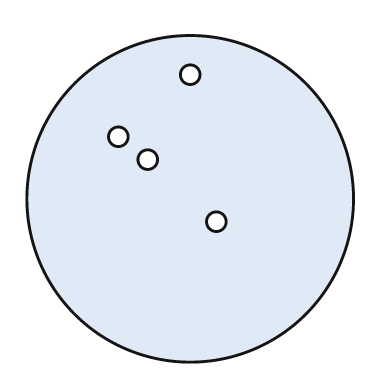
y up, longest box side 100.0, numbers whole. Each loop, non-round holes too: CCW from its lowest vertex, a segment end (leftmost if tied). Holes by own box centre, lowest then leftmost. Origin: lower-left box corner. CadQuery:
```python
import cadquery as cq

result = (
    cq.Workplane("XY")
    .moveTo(50.0, 50.0)
    .circle(50.0)
    .moveTo(58.0, 43.0)
    .circle(3.0)
    .moveTo(37.0, 62.0)
    .circle(3.0)
    .moveTo(28.0, 69.0)
    .circle(3.0)
    .moveTo(50.0, 88.0)
    .circle(3.0)
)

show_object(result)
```